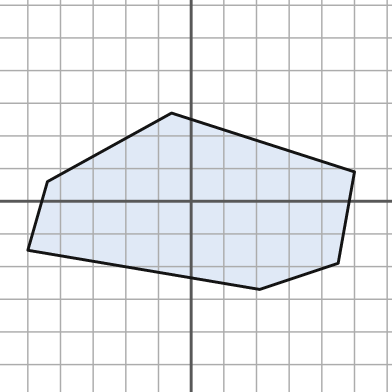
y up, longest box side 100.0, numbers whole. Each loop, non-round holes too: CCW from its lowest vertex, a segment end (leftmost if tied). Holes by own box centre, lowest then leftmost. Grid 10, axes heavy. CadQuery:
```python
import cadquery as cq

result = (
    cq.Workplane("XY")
    .moveTo(21.0, -27.0)
    .lineTo(45.0, -19.0)
    .lineTo(50.0, 9.0)
    .lineTo(-6.0, 27.0)
    .lineTo(-44.0, 6.0)
    .lineTo(-50.0, -15.0)
    .close()
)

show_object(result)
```